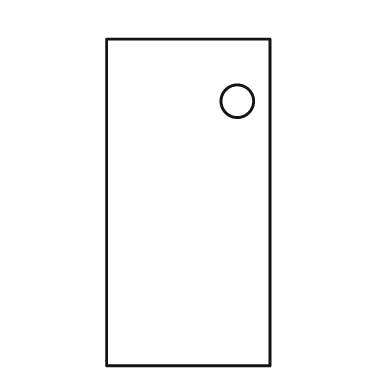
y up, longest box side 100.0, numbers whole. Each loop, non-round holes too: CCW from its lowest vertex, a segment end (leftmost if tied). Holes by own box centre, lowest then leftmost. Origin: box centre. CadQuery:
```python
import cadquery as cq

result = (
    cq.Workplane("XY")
    .moveTo(-25.0, -50.0)
    .lineTo(25.0, -50.0)
    .lineTo(25.0, 50.0)
    .lineTo(-25.0, 50.0)
    .close()
    .moveTo(15.0, 31.0)
    .circle(5.0)
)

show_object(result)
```